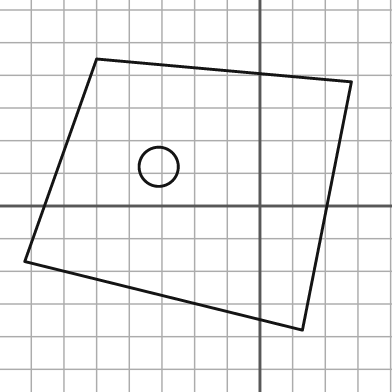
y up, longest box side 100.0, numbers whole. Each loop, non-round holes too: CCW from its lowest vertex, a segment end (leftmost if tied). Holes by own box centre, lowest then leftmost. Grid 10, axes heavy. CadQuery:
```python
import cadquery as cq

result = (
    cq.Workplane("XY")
    .moveTo(13.0, -38.0)
    .lineTo(28.0, 38.0)
    .lineTo(-50.0, 45.0)
    .lineTo(-72.0, -17.0)
    .close()
    .moveTo(-31.0, 12.0)
    .circle(6.0)
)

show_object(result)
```